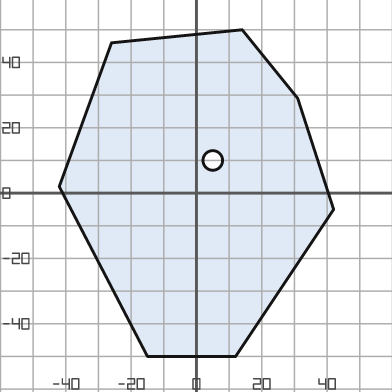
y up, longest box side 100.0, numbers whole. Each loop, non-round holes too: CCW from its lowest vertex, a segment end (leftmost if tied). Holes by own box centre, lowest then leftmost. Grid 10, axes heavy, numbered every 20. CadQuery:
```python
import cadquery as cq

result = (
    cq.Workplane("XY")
    .moveTo(-15.0, -50.0)
    .lineTo(12.0, -50.0)
    .lineTo(42.0, -5.0)
    .lineTo(31.0, 29.0)
    .lineTo(14.0, 50.0)
    .lineTo(-26.0, 46.0)
    .lineTo(-42.0, 2.0)
    .close()
    .moveTo(5.0, 10.0)
    .circle(3.0)
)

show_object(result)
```